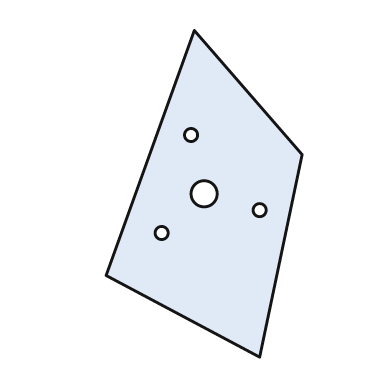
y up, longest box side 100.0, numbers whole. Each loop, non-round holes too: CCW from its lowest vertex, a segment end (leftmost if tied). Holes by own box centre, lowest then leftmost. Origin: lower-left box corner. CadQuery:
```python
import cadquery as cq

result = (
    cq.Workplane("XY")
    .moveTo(47.0, 0.0)
    .lineTo(60.0, 62.0)
    .lineTo(27.0, 100.0)
    .lineTo(0.0, 25.0)
    .close()
    .moveTo(17.0, 38.0)
    .circle(2.0)
    .moveTo(47.0, 45.0)
    .circle(2.0)
    .moveTo(30.0, 50.0)
    .circle(4.0)
    .moveTo(26.0, 68.0)
    .circle(2.0)
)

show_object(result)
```